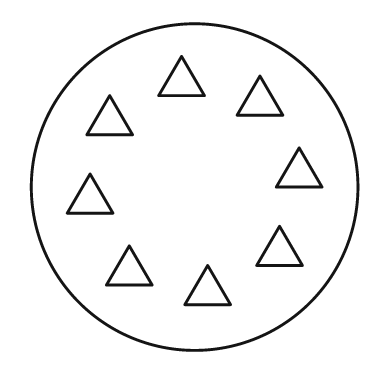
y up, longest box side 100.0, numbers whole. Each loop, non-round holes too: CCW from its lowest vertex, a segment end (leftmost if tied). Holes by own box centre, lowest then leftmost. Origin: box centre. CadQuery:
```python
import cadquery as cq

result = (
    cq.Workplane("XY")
    .moveTo(0.0, 0.0)
    .circle(50.0)
    .moveTo(-3.0, -36.0)
    .lineTo(11.0, -36.0)
    .lineTo(4.0, -24.0)
    .close()
    .moveTo(-27.0, -30.0)
    .lineTo(-13.0, -30.0)
    .lineTo(-20.0, -18.0)
    .close()
    .moveTo(19.0, -24.0)
    .lineTo(33.0, -24.0)
    .lineTo(26.0, -12.0)
    .close()
    .moveTo(-39.0, -8.0)
    .lineTo(-25.0, -8.0)
    .lineTo(-32.0, 4.0)
    .close()
    .moveTo(25.0, 0.0)
    .lineTo(39.0, 0.0)
    .lineTo(32.0, 12.0)
    .close()
    .moveTo(-33.0, 16.0)
    .lineTo(-19.0, 16.0)
    .lineTo(-26.0, 28.0)
    .close()
    .moveTo(13.0, 22.0)
    .lineTo(27.0, 22.0)
    .lineTo(20.0, 34.0)
    .close()
    .moveTo(-11.0, 28.0)
    .lineTo(3.0, 28.0)
    .lineTo(-4.0, 40.0)
    .close()
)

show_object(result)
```